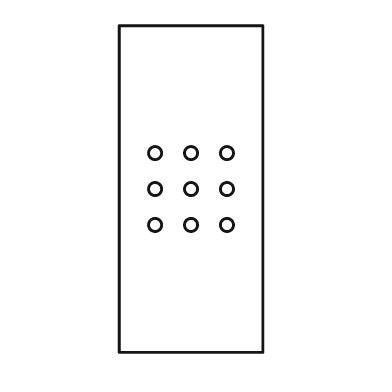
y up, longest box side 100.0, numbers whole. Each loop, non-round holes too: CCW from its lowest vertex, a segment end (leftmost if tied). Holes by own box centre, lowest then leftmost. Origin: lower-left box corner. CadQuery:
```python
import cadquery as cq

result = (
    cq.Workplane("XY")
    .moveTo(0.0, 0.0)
    .lineTo(44.0, 0.0)
    .lineTo(44.0, 100.0)
    .lineTo(0.0, 100.0)
    .close()
    .moveTo(11.0, 39.0)
    .circle(2.0)
    .moveTo(22.0, 39.0)
    .circle(2.0)
    .moveTo(33.0, 39.0)
    .circle(2.0)
    .moveTo(11.0, 50.0)
    .circle(2.0)
    .moveTo(22.0, 50.0)
    .circle(2.0)
    .moveTo(33.0, 50.0)
    .circle(2.0)
    .moveTo(11.0, 61.0)
    .circle(2.0)
    .moveTo(22.0, 61.0)
    .circle(2.0)
    .moveTo(33.0, 61.0)
    .circle(2.0)
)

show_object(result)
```